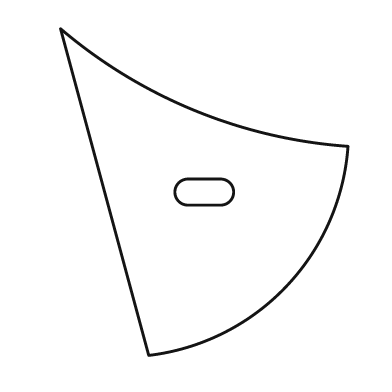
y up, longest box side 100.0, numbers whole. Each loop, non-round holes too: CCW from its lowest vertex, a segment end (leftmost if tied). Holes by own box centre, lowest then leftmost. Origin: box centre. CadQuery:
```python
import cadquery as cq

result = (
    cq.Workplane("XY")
    .moveTo(-17.0, -50.0)
    .threePointArc((25.0, -29.0), (44.0, 14.0))
    .threePointArc((-3.0, 25.0), (-44.0, 50.0))
    .close()
    .moveTo(-5.0, -4.0)
    .lineTo(5.0, -4.0)
    .threePointArc((9.0, 0.0), (5.0, 4.0))
    .lineTo(-5.0, 4.0)
    .threePointArc((-9.0, 0.0), (-5.0, -4.0))
    .close()
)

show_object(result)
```